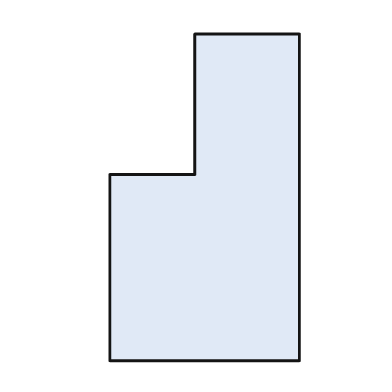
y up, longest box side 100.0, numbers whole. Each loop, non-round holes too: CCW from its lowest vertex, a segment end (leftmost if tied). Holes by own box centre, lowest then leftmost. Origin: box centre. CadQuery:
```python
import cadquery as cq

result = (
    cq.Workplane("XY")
    .moveTo(-29.0, -50.0)
    .lineTo(29.0, -50.0)
    .lineTo(29.0, 50.0)
    .lineTo(-3.0, 50.0)
    .lineTo(-3.0, 7.0)
    .lineTo(-29.0, 7.0)
    .close()
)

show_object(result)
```